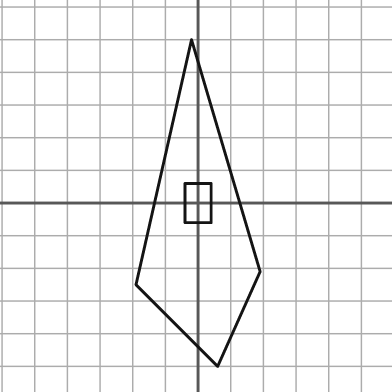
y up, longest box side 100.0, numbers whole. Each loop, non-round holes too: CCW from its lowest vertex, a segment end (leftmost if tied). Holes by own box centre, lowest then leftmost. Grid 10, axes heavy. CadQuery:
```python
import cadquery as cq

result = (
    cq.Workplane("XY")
    .moveTo(6.0, -50.0)
    .lineTo(19.0, -21.0)
    .lineTo(-2.0, 50.0)
    .lineTo(-19.0, -25.0)
    .close()
    .moveTo(-4.0, -6.0)
    .lineTo(4.0, -6.0)
    .lineTo(4.0, 6.0)
    .lineTo(-4.0, 6.0)
    .close()
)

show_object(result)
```